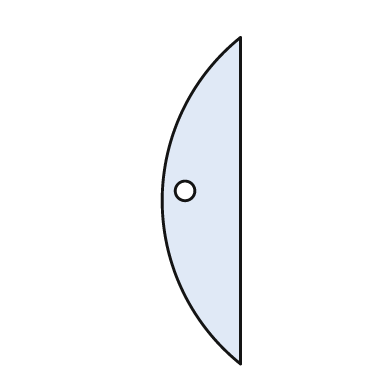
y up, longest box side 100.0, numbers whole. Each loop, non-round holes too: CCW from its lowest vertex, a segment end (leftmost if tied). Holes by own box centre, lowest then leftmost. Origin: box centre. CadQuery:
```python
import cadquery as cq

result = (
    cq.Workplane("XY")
    .moveTo(12.0, -50.0)
    .lineTo(12.0, 50.0)
    .threePointArc((-12.0, 0.0), (12.0, -50.0))
    .close()
    .moveTo(-5.0, 3.0)
    .circle(3.0)
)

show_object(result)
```